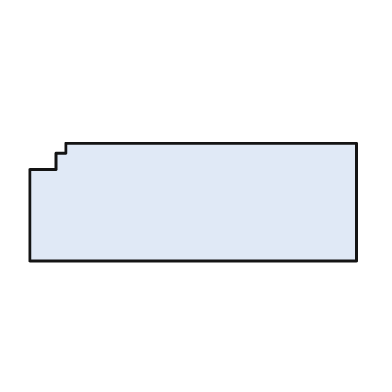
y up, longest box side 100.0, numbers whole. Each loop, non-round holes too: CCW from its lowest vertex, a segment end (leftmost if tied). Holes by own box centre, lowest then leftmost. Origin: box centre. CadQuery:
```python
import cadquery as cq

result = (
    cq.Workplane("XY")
    .moveTo(-50.0, -18.0)
    .lineTo(50.0, -18.0)
    .lineTo(50.0, 18.0)
    .lineTo(-39.0, 18.0)
    .lineTo(-39.0, 15.0)
    .lineTo(-42.0, 15.0)
    .lineTo(-42.0, 10.0)
    .lineTo(-50.0, 10.0)
    .close()
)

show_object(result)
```